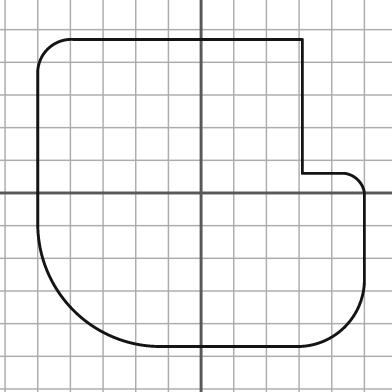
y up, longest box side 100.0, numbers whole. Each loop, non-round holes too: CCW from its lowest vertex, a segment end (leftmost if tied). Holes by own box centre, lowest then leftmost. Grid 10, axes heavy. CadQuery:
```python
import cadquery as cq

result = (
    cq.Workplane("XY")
    .moveTo(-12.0, -47.0)
    .lineTo(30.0, -47.0)
    .threePointArc((44.0, -41.0), (50.0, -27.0))
    .lineTo(50.0, 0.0)
    .threePointArc((48.0, 4.0), (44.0, 6.0))
    .lineTo(31.0, 6.0)
    .lineTo(31.0, 47.0)
    .lineTo(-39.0, 47.0)
    .threePointArc((-47.0, 44.0), (-50.0, 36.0))
    .lineTo(-50.0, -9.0)
    .threePointArc((-39.0, -36.0), (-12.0, -47.0))
    .close()
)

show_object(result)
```